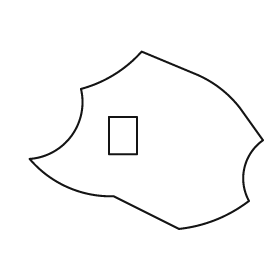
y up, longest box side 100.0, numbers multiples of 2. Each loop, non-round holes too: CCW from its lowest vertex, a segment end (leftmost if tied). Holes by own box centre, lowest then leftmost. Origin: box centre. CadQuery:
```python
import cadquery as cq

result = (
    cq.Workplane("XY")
    .moveTo(14.0, -38.0)
    .threePointArc((30.0, -34.0), (44.0, -26.0))
    .threePointArc((42.0, -12.0), (50.0, 0.0))
    .lineTo(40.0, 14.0)
    .threePointArc((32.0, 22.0), (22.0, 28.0))
    .lineTo(-2.0, 38.0)
    .threePointArc((-14.0, 28.0), (-28.0, 22.0))
    .threePointArc((-32.0, 2.0), (-50.0, -8.0))
    .threePointArc((-34.0, -20.0), (-14.0, -24.0))
    .close()
    .moveTo(-16.0, -6.0)
    .lineTo(-4.0, -6.0)
    .lineTo(-4.0, 10.0)
    .lineTo(-16.0, 10.0)
    .close()
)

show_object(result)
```